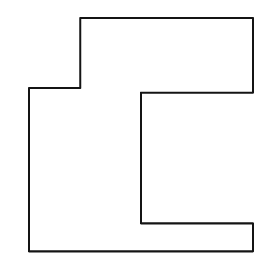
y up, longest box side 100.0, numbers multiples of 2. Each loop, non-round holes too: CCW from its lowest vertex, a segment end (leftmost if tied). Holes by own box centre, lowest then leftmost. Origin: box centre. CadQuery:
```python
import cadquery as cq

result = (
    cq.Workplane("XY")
    .moveTo(-48.0, -50.0)
    .lineTo(48.0, -50.0)
    .lineTo(48.0, -38.0)
    .lineTo(0.0, -38.0)
    .lineTo(0.0, 18.0)
    .lineTo(48.0, 18.0)
    .lineTo(48.0, 50.0)
    .lineTo(-26.0, 50.0)
    .lineTo(-26.0, 20.0)
    .lineTo(-48.0, 20.0)
    .close()
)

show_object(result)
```